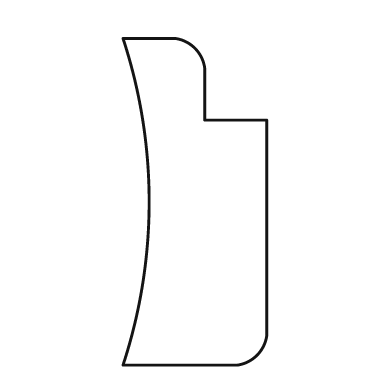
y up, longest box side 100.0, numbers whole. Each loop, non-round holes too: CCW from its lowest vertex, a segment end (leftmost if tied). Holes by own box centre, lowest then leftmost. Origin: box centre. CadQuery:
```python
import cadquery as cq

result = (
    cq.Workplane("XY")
    .moveTo(-22.0, -50.0)
    .lineTo(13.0, -50.0)
    .threePointArc((19.0, -47.0), (22.0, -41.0))
    .lineTo(22.0, 25.0)
    .lineTo(3.0, 25.0)
    .lineTo(3.0, 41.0)
    .threePointArc((0.0, 47.0), (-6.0, 50.0))
    .lineTo(-22.0, 50.0)
    .threePointArc((-14.0, 0.0), (-22.0, -50.0))
    .close()
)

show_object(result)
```